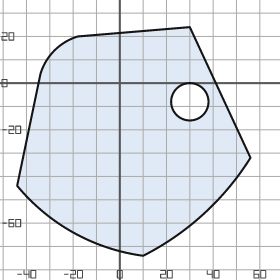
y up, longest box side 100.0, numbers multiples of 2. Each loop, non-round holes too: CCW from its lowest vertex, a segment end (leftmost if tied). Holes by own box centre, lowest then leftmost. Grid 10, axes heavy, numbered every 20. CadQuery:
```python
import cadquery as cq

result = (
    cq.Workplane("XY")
    .moveTo(10.0, -74.0)
    .threePointArc((36.0, -56.0), (56.0, -32.0))
    .lineTo(30.0, 24.0)
    .lineTo(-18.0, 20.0)
    .threePointArc((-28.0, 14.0), (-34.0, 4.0))
    .lineTo(-44.0, -44.0)
    .threePointArc((-20.0, -64.0), (10.0, -74.0))
    .close()
    .moveTo(30.0, -8.0)
    .circle(8.0)
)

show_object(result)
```